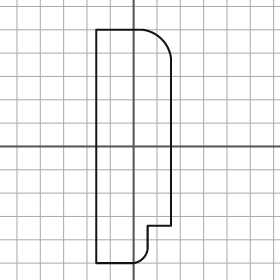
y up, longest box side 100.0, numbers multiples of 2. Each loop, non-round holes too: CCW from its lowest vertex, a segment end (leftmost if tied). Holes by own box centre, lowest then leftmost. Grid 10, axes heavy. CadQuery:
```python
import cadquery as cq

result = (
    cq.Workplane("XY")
    .moveTo(-16.0, -50.0)
    .lineTo(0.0, -50.0)
    .threePointArc((4.0, -48.0), (6.0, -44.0))
    .lineTo(6.0, -34.0)
    .lineTo(16.0, -34.0)
    .lineTo(16.0, 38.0)
    .threePointArc((12.0, 46.0), (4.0, 50.0))
    .lineTo(-16.0, 50.0)
    .close()
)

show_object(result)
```